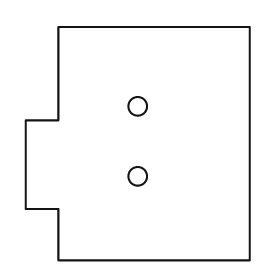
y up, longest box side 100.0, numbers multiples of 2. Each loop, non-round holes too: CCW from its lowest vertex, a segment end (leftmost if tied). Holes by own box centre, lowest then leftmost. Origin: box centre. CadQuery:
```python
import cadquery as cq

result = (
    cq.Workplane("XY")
    .moveTo(-34.0, -50.0)
    .lineTo(48.0, -50.0)
    .lineTo(48.0, 50.0)
    .lineTo(-34.0, 50.0)
    .lineTo(-34.0, 10.0)
    .lineTo(-48.0, 10.0)
    .lineTo(-48.0, -28.0)
    .lineTo(-34.0, -28.0)
    .close()
    .moveTo(0.0, -14.0)
    .circle(4.0)
    .moveTo(0.0, 16.0)
    .circle(4.0)
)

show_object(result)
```